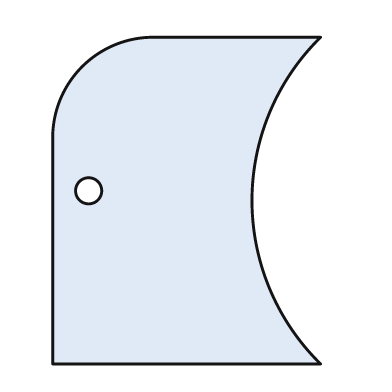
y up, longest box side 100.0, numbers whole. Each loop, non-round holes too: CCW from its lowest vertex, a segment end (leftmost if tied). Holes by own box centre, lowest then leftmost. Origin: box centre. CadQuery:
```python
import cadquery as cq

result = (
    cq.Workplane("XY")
    .moveTo(-41.0, -50.0)
    .lineTo(41.0, -50.0)
    .threePointArc((20.0, 0.0), (41.0, 50.0))
    .lineTo(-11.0, 50.0)
    .threePointArc((-32.0, 41.0), (-41.0, 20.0))
    .close()
    .moveTo(-30.0, 3.0)
    .circle(4.0)
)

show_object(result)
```